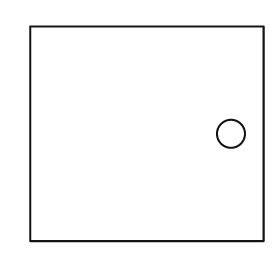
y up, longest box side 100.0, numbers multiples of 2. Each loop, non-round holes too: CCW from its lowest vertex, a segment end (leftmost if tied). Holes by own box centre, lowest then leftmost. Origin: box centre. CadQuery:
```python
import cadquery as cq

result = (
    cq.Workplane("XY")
    .moveTo(-50.0, -46.0)
    .lineTo(50.0, -46.0)
    .lineTo(50.0, 46.0)
    .lineTo(-50.0, 46.0)
    .close()
    .moveTo(36.0, 0.0)
    .circle(6.0)
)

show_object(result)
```